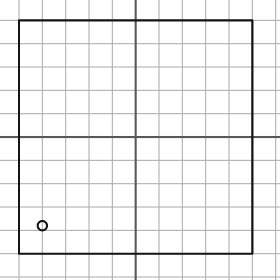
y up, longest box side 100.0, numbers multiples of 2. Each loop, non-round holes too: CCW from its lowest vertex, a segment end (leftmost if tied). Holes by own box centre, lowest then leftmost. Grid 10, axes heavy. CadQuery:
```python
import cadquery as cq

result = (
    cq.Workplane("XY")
    .moveTo(-50.0, -50.0)
    .lineTo(50.0, -50.0)
    .lineTo(50.0, 50.0)
    .lineTo(-50.0, 50.0)
    .close()
    .moveTo(-40.0, -38.0)
    .circle(2.0)
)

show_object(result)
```